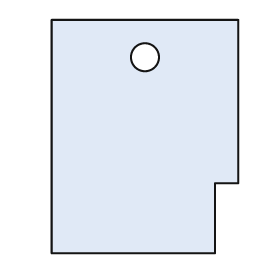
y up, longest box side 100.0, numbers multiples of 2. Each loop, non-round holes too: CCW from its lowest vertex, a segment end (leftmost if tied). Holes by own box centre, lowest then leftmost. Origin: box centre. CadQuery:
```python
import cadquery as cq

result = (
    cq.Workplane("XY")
    .moveTo(-40.0, -50.0)
    .lineTo(30.0, -50.0)
    .lineTo(30.0, -20.0)
    .lineTo(40.0, -20.0)
    .lineTo(40.0, 50.0)
    .lineTo(-40.0, 50.0)
    .close()
    .moveTo(0.0, 34.0)
    .circle(6.0)
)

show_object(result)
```